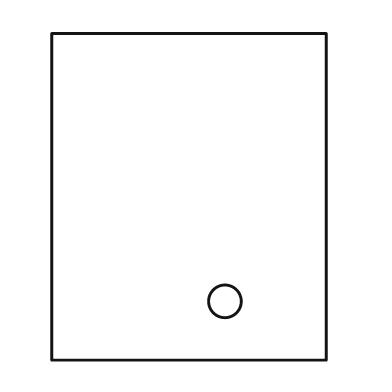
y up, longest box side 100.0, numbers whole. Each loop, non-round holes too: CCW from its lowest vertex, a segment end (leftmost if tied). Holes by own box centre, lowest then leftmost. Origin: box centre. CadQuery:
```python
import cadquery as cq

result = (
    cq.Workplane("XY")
    .moveTo(-42.0, -50.0)
    .lineTo(42.0, -50.0)
    .lineTo(42.0, 50.0)
    .lineTo(-42.0, 50.0)
    .close()
    .moveTo(11.0, -32.0)
    .circle(5.0)
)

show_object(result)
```